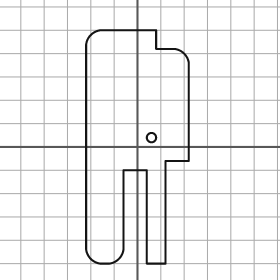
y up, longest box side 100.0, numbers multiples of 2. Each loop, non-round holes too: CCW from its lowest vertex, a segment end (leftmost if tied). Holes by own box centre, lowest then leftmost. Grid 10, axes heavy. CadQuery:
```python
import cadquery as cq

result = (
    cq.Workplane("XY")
    .moveTo(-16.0, -50.0)
    .lineTo(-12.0, -50.0)
    .threePointArc((-8.0, -48.0), (-6.0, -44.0))
    .lineTo(-6.0, -10.0)
    .lineTo(4.0, -10.0)
    .lineTo(4.0, -50.0)
    .lineTo(12.0, -50.0)
    .lineTo(12.0, -6.0)
    .lineTo(22.0, -6.0)
    .lineTo(22.0, 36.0)
    .threePointArc((20.0, 40.0), (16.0, 42.0))
    .lineTo(8.0, 42.0)
    .lineTo(8.0, 50.0)
    .lineTo(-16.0, 50.0)
    .threePointArc((-20.0, 48.0), (-22.0, 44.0))
    .lineTo(-22.0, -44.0)
    .threePointArc((-20.0, -48.0), (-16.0, -50.0))
    .close()
    .moveTo(6.0, 4.0)
    .circle(2.0)
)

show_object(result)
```